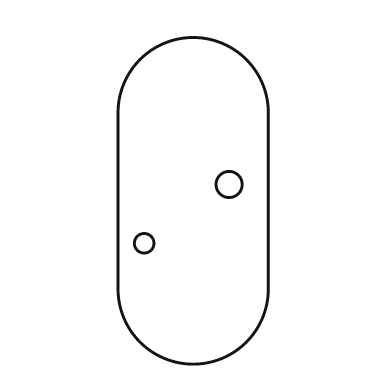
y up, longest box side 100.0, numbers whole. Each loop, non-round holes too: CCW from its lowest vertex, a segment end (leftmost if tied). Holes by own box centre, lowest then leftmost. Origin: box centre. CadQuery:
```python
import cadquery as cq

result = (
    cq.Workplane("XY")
    .moveTo(-23.0, -27.0)
    .threePointArc((0.0, -50.0), (23.0, -27.0))
    .lineTo(23.0, 27.0)
    .threePointArc((0.0, 50.0), (-23.0, 27.0))
    .close()
    .moveTo(-15.0, -13.0)
    .circle(3.0)
    .moveTo(11.0, 5.0)
    .circle(4.0)
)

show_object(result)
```